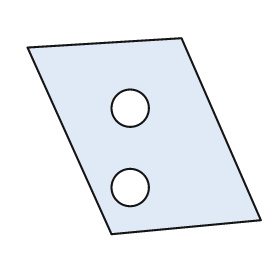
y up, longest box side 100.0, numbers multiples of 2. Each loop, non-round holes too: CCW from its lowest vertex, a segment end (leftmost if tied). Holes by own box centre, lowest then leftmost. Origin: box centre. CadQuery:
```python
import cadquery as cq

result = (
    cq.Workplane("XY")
    .moveTo(-14.0, -42.0)
    .lineTo(50.0, -36.0)
    .lineTo(16.0, 42.0)
    .lineTo(-50.0, 38.0)
    .close()
    .moveTo(-6.0, -22.0)
    .circle(8.0)
    .moveTo(-6.0, 12.0)
    .circle(8.0)
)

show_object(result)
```